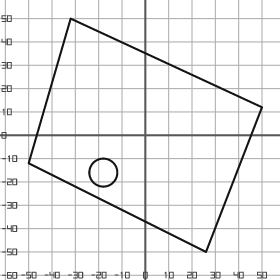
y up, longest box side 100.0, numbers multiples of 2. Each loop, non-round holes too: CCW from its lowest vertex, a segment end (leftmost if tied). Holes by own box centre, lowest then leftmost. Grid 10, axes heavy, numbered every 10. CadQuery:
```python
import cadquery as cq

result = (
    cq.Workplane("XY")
    .moveTo(26.0, -50.0)
    .lineTo(50.0, 12.0)
    .lineTo(-32.0, 50.0)
    .lineTo(-50.0, -12.0)
    .close()
    .moveTo(-18.0, -16.0)
    .circle(6.0)
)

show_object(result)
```